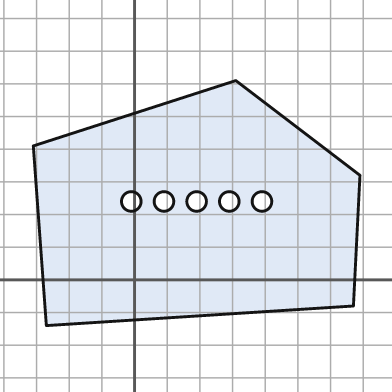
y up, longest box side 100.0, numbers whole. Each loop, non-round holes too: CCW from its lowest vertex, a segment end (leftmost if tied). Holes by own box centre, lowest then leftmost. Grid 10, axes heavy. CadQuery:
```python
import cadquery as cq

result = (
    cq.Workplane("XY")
    .moveTo(-27.0, -14.0)
    .lineTo(67.0, -8.0)
    .lineTo(69.0, 32.0)
    .lineTo(31.0, 61.0)
    .lineTo(-31.0, 41.0)
    .close()
    .moveTo(-1.0, 24.0)
    .circle(3.0)
    .moveTo(9.0, 24.0)
    .circle(3.0)
    .moveTo(19.0, 24.0)
    .circle(3.0)
    .moveTo(29.0, 24.0)
    .circle(3.0)
    .moveTo(39.0, 24.0)
    .circle(3.0)
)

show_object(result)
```